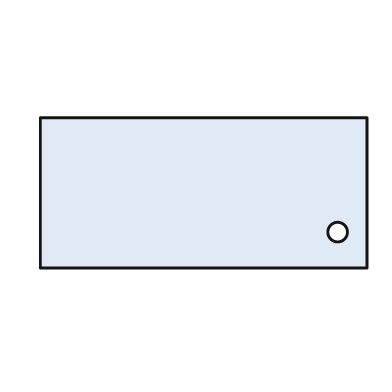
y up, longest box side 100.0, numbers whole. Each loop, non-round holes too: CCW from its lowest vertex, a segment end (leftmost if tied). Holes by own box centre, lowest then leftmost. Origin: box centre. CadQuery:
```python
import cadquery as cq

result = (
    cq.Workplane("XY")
    .moveTo(-50.0, -23.0)
    .lineTo(50.0, -23.0)
    .lineTo(50.0, 23.0)
    .lineTo(-50.0, 23.0)
    .close()
    .moveTo(41.0, -12.0)
    .circle(3.0)
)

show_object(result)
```